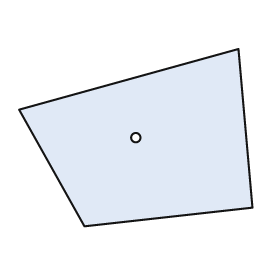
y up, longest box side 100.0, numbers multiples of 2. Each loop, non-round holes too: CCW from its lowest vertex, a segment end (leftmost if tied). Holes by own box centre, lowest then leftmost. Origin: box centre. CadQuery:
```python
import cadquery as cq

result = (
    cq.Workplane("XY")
    .moveTo(-22.0, -38.0)
    .lineTo(50.0, -30.0)
    .lineTo(44.0, 38.0)
    .lineTo(-50.0, 12.0)
    .close()
    .moveTo(0.0, 0.0)
    .circle(2.0)
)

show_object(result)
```